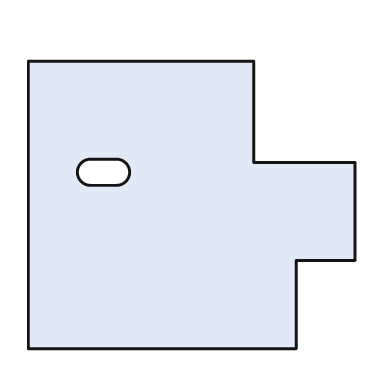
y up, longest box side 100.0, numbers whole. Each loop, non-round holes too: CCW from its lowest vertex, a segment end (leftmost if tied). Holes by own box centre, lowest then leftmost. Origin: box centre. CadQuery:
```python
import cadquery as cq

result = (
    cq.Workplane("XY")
    .moveTo(-50.0, -44.0)
    .lineTo(32.0, -44.0)
    .lineTo(32.0, -17.0)
    .lineTo(50.0, -17.0)
    .lineTo(50.0, 13.0)
    .lineTo(19.0, 13.0)
    .lineTo(19.0, 44.0)
    .lineTo(-50.0, 44.0)
    .close()
    .moveTo(-31.0, 6.0)
    .lineTo(-23.0, 6.0)
    .threePointArc((-19.0, 10.0), (-23.0, 14.0))
    .lineTo(-31.0, 14.0)
    .threePointArc((-35.0, 10.0), (-31.0, 6.0))
    .close()
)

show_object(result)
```